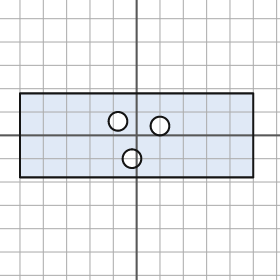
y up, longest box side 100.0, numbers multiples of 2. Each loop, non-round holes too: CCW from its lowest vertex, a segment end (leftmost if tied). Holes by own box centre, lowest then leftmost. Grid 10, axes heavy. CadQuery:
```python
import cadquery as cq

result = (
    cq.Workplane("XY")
    .moveTo(-50.0, -18.0)
    .lineTo(50.0, -18.0)
    .lineTo(50.0, 18.0)
    .lineTo(-50.0, 18.0)
    .close()
    .moveTo(-2.0, -10.0)
    .circle(4.0)
    .moveTo(10.0, 4.0)
    .circle(4.0)
    .moveTo(-8.0, 6.0)
    .circle(4.0)
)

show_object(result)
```